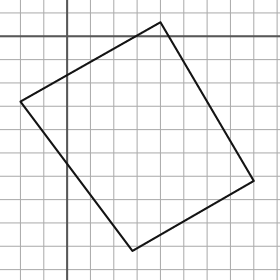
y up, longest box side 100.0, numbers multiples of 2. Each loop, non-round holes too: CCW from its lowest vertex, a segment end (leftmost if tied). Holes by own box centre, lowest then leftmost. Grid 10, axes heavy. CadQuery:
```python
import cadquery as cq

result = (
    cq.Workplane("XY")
    .moveTo(28.0, -92.0)
    .lineTo(80.0, -62.0)
    .lineTo(40.0, 6.0)
    .lineTo(-20.0, -28.0)
    .close()
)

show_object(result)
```